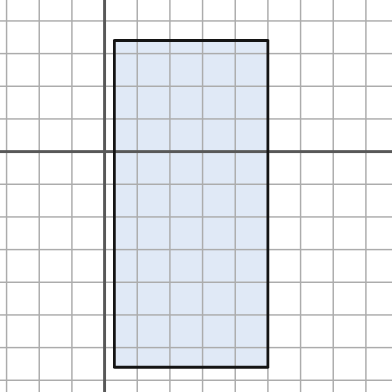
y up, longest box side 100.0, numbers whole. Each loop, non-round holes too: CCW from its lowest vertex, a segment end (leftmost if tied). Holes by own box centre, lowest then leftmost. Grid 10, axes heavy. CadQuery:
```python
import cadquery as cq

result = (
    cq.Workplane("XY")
    .moveTo(3.0, -66.0)
    .lineTo(50.0, -66.0)
    .lineTo(50.0, 34.0)
    .lineTo(3.0, 34.0)
    .close()
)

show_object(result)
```